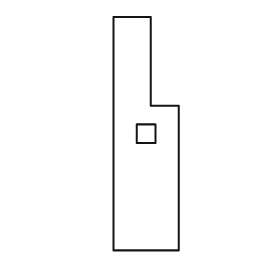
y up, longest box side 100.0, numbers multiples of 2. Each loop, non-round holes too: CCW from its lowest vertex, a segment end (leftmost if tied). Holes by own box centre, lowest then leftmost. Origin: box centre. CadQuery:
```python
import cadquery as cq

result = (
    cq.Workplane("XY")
    .moveTo(-14.0, -50.0)
    .lineTo(14.0, -50.0)
    .lineTo(14.0, 12.0)
    .lineTo(2.0, 12.0)
    .lineTo(2.0, 50.0)
    .lineTo(-14.0, 50.0)
    .close()
    .moveTo(-4.0, -4.0)
    .lineTo(4.0, -4.0)
    .lineTo(4.0, 4.0)
    .lineTo(-4.0, 4.0)
    .close()
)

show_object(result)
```